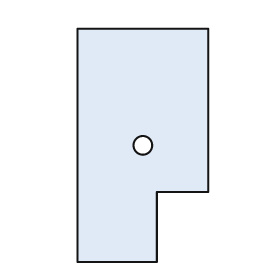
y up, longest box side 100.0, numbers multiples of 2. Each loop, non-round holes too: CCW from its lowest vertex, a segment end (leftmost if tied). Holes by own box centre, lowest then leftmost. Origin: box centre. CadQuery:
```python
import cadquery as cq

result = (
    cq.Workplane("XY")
    .moveTo(-28.0, -50.0)
    .lineTo(6.0, -50.0)
    .lineTo(6.0, -20.0)
    .lineTo(28.0, -20.0)
    .lineTo(28.0, 50.0)
    .lineTo(-28.0, 50.0)
    .close()
    .moveTo(0.0, 0.0)
    .circle(4.0)
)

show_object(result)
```